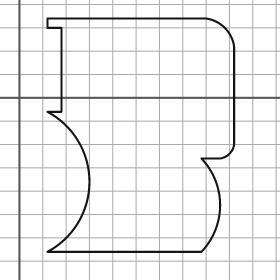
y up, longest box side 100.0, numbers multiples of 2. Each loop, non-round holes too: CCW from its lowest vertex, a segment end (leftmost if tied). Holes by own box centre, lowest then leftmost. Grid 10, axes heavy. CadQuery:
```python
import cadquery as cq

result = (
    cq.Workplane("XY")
    .moveTo(12.0, -66.0)
    .lineTo(78.0, -66.0)
    .threePointArc((86.0, -46.0), (78.0, -26.0))
    .lineTo(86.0, -26.0)
    .threePointArc((90.0, -24.0), (92.0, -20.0))
    .lineTo(92.0, 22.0)
    .threePointArc((88.0, 30.0), (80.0, 34.0))
    .lineTo(12.0, 34.0)
    .lineTo(12.0, 30.0)
    .lineTo(18.0, 30.0)
    .lineTo(18.0, -6.0)
    .lineTo(12.0, -6.0)
    .threePointArc((30.0, -36.0), (12.0, -66.0))
    .close()
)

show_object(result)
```